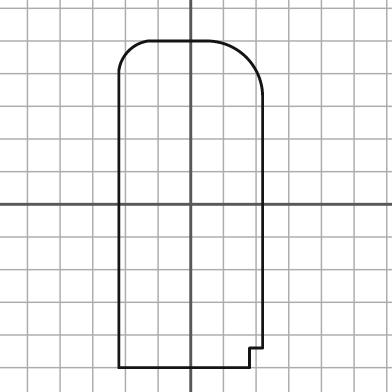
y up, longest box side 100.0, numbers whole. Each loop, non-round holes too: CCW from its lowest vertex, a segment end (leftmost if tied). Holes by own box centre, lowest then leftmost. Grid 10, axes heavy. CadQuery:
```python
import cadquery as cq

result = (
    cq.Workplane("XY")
    .moveTo(-22.0, -50.0)
    .lineTo(18.0, -50.0)
    .lineTo(18.0, -44.0)
    .lineTo(22.0, -44.0)
    .lineTo(22.0, 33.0)
    .threePointArc((17.0, 45.0), (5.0, 50.0))
    .lineTo(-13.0, 50.0)
    .threePointArc((-19.0, 47.0), (-22.0, 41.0))
    .close()
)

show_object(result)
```